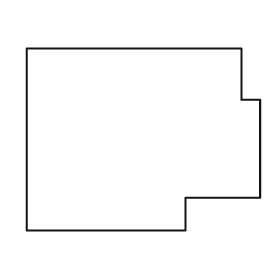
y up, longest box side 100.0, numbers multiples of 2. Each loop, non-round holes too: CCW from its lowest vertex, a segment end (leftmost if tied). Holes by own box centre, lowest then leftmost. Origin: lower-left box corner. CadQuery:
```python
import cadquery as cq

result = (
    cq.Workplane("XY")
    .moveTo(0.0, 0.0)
    .lineTo(68.0, 0.0)
    .lineTo(68.0, 14.0)
    .lineTo(100.0, 14.0)
    .lineTo(100.0, 56.0)
    .lineTo(92.0, 56.0)
    .lineTo(92.0, 78.0)
    .lineTo(0.0, 78.0)
    .close()
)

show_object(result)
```